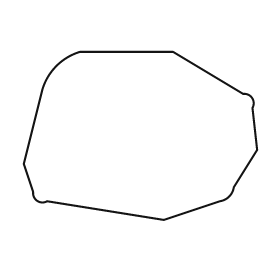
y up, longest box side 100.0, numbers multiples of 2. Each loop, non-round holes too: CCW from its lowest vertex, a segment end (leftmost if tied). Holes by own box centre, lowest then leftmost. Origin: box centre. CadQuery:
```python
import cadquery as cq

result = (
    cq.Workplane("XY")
    .moveTo(10.0, -36.0)
    .lineTo(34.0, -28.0)
    .threePointArc((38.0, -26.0), (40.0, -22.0))
    .lineTo(50.0, -6.0)
    .lineTo(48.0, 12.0)
    .threePointArc((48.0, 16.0), (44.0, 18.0))
    .lineTo(14.0, 36.0)
    .lineTo(-26.0, 36.0)
    .threePointArc((-36.0, 30.0), (-42.0, 20.0))
    .lineTo(-50.0, -12.0)
    .lineTo(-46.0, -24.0)
    .threePointArc((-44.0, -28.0), (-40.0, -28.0))
    .close()
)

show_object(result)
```